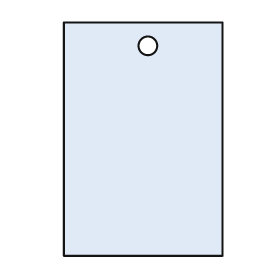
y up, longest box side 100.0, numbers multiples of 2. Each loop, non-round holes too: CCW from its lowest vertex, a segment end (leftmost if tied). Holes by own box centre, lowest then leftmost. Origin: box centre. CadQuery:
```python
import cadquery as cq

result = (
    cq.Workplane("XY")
    .moveTo(-34.0, -50.0)
    .lineTo(34.0, -50.0)
    .lineTo(34.0, 50.0)
    .lineTo(-34.0, 50.0)
    .close()
    .moveTo(2.0, 40.0)
    .circle(4.0)
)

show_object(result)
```